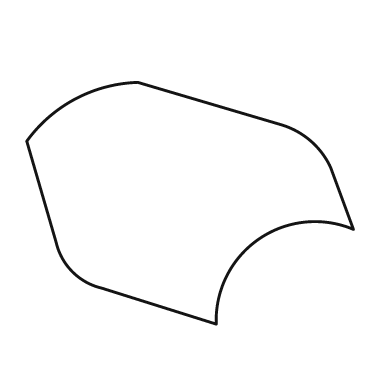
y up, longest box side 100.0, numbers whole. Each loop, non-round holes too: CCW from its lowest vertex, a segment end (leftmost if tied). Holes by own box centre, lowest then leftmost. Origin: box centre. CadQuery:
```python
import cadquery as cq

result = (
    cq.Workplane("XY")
    .moveTo(8.0, -37.0)
    .threePointArc((21.0, -11.0), (50.0, -8.0))
    .lineTo(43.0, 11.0)
    .threePointArc((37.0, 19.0), (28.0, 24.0))
    .lineTo(-16.0, 37.0)
    .threePointArc((-35.0, 32.0), (-50.0, 19.0))
    .lineTo(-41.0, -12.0)
    .threePointArc((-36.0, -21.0), (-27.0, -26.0))
    .close()
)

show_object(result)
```